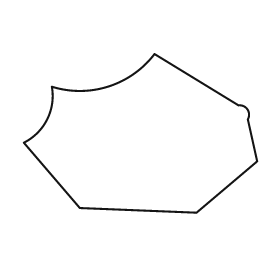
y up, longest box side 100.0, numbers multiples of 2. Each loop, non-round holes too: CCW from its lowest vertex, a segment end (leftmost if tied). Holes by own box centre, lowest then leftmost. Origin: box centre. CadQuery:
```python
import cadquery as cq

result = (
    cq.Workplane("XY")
    .moveTo(24.0, -34.0)
    .lineTo(50.0, -12.0)
    .lineTo(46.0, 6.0)
    .threePointArc((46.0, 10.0), (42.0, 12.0))
    .lineTo(6.0, 34.0)
    .threePointArc((-14.0, 20.0), (-38.0, 20.0))
    .threePointArc((-40.0, 6.0), (-50.0, -4.0))
    .lineTo(-26.0, -32.0)
    .close()
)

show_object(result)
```